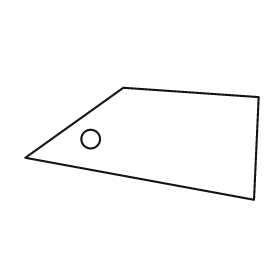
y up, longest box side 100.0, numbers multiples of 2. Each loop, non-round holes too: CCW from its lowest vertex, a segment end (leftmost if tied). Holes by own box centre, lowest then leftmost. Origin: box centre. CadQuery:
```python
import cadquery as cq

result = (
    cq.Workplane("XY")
    .moveTo(48.0, -24.0)
    .lineTo(50.0, 20.0)
    .lineTo(-8.0, 24.0)
    .lineTo(-50.0, -6.0)
    .close()
    .moveTo(-22.0, 2.0)
    .circle(4.0)
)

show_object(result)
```